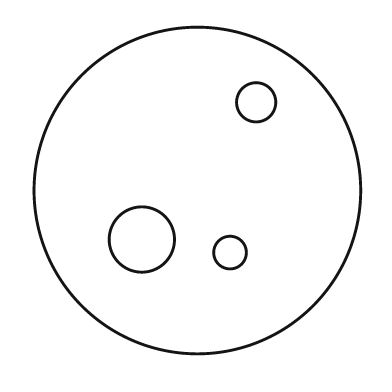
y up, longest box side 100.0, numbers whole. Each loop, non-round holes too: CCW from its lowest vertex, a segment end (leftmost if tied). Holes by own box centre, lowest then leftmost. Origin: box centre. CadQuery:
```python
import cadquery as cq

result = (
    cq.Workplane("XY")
    .moveTo(0.0, 0.0)
    .circle(50.0)
    .moveTo(10.0, -19.0)
    .circle(5.0)
    .moveTo(-17.0, -15.0)
    .circle(10.0)
    .moveTo(18.0, 27.0)
    .circle(6.0)
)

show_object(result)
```